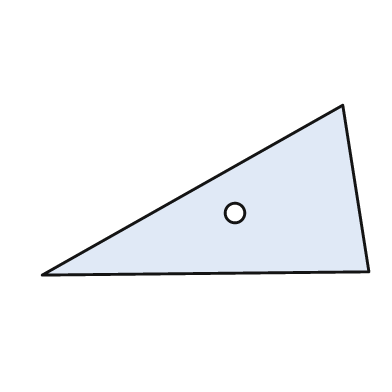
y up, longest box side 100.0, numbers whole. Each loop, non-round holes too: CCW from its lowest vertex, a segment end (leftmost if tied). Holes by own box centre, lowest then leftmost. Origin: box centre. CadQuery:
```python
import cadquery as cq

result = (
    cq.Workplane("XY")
    .moveTo(-50.0, -26.0)
    .lineTo(50.0, -25.0)
    .lineTo(42.0, 26.0)
    .close()
    .moveTo(9.0, -7.0)
    .circle(3.0)
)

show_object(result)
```